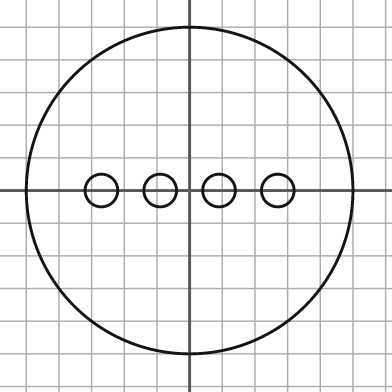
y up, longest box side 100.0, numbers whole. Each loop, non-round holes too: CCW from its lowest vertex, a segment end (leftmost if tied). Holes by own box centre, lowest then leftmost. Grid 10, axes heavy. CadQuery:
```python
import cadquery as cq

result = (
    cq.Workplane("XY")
    .moveTo(0.0, 0.0)
    .circle(50.0)
    .moveTo(-27.0, 0.0)
    .circle(5.0)
    .moveTo(-9.0, 0.0)
    .circle(5.0)
    .moveTo(9.0, 0.0)
    .circle(5.0)
    .moveTo(27.0, 0.0)
    .circle(5.0)
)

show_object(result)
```